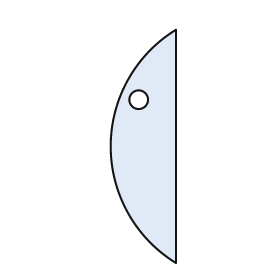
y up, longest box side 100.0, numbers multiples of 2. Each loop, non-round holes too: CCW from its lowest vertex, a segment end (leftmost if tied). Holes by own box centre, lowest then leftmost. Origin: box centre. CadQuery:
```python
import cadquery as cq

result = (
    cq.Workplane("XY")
    .moveTo(14.0, -50.0)
    .lineTo(14.0, 50.0)
    .threePointArc((-14.0, 0.0), (14.0, -50.0))
    .close()
    .moveTo(-2.0, 20.0)
    .circle(4.0)
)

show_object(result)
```